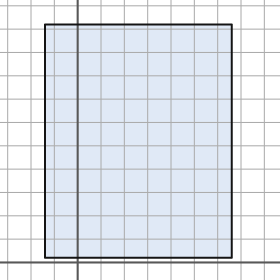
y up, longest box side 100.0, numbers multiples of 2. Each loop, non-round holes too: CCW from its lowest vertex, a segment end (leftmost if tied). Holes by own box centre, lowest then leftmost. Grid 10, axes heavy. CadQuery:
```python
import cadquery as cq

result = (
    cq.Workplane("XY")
    .moveTo(-14.0, 2.0)
    .lineTo(66.0, 2.0)
    .lineTo(66.0, 102.0)
    .lineTo(-14.0, 102.0)
    .close()
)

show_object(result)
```